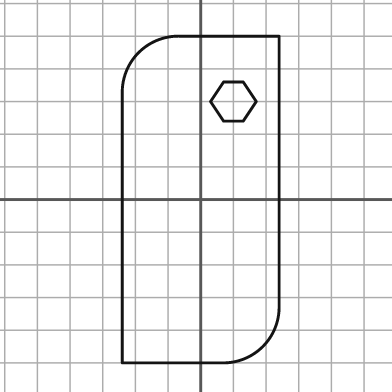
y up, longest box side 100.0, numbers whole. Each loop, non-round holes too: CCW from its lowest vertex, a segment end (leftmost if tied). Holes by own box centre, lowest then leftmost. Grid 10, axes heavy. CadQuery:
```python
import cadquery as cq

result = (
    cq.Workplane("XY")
    .moveTo(-24.0, -50.0)
    .lineTo(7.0, -50.0)
    .threePointArc((19.0, -45.0), (24.0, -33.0))
    .lineTo(24.0, 50.0)
    .lineTo(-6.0, 50.0)
    .threePointArc((-19.0, 45.0), (-24.0, 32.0))
    .close()
    .moveTo(7.0, 24.0)
    .lineTo(13.0, 24.0)
    .lineTo(17.0, 30.0)
    .lineTo(13.0, 36.0)
    .lineTo(7.0, 36.0)
    .lineTo(3.0, 30.0)
    .close()
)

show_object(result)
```